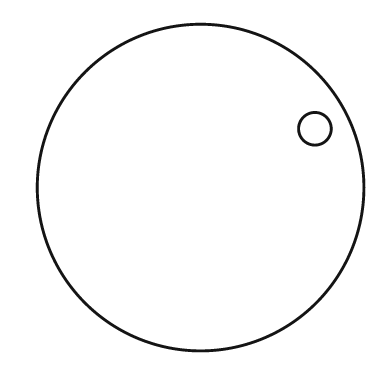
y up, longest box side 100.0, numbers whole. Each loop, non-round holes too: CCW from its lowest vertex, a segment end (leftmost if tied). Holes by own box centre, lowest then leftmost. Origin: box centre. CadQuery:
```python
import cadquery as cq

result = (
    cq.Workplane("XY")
    .moveTo(0.0, 0.0)
    .circle(50.0)
    .moveTo(35.0, 18.0)
    .circle(5.0)
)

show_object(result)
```